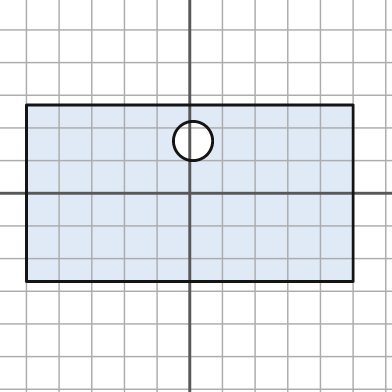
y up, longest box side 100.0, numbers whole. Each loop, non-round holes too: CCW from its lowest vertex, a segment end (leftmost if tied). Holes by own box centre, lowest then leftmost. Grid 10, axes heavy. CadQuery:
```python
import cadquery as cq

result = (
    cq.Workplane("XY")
    .moveTo(-50.0, -27.0)
    .lineTo(50.0, -27.0)
    .lineTo(50.0, 27.0)
    .lineTo(-50.0, 27.0)
    .close()
    .moveTo(1.0, 16.0)
    .circle(6.0)
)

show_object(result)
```